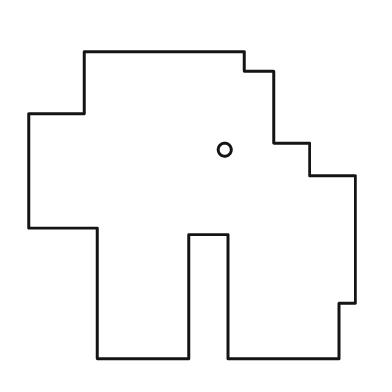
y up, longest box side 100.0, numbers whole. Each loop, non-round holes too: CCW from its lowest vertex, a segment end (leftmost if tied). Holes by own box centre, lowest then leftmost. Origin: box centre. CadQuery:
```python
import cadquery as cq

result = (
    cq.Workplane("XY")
    .moveTo(-29.0, -47.0)
    .lineTo(-1.0, -47.0)
    .lineTo(-1.0, -9.0)
    .lineTo(11.0, -9.0)
    .lineTo(11.0, -47.0)
    .lineTo(45.0, -47.0)
    .lineTo(45.0, -30.0)
    .lineTo(50.0, -30.0)
    .lineTo(50.0, 9.0)
    .lineTo(36.0, 9.0)
    .lineTo(36.0, 19.0)
    .lineTo(25.0, 19.0)
    .lineTo(25.0, 41.0)
    .lineTo(16.0, 41.0)
    .lineTo(16.0, 47.0)
    .lineTo(-33.0, 47.0)
    .lineTo(-33.0, 28.0)
    .lineTo(-50.0, 28.0)
    .lineTo(-50.0, -7.0)
    .lineTo(-29.0, -7.0)
    .close()
    .moveTo(10.0, 17.0)
    .circle(2.0)
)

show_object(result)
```